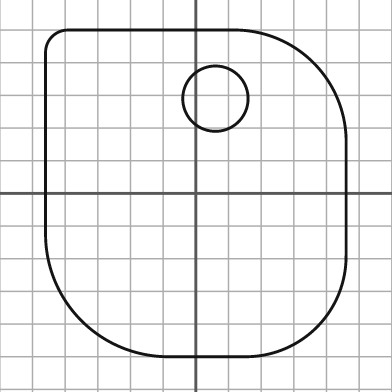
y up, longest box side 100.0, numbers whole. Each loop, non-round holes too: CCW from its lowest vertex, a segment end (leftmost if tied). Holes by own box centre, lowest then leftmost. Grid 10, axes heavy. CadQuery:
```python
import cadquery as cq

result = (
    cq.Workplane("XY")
    .moveTo(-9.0, -50.0)
    .lineTo(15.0, -50.0)
    .threePointArc((37.0, -41.0), (46.0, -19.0))
    .lineTo(46.0, 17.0)
    .threePointArc((36.0, 40.0), (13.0, 50.0))
    .lineTo(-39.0, 50.0)
    .threePointArc((-44.0, 48.0), (-46.0, 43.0))
    .lineTo(-46.0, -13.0)
    .threePointArc((-35.0, -39.0), (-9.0, -50.0))
    .close()
    .moveTo(6.0, 29.0)
    .circle(10.0)
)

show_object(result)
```